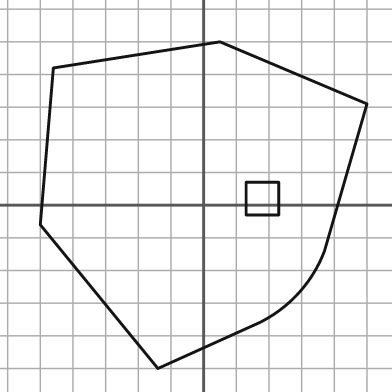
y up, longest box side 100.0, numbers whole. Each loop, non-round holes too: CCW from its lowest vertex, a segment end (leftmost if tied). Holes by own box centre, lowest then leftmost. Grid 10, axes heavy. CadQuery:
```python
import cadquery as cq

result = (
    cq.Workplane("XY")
    .moveTo(-14.0, -50.0)
    .lineTo(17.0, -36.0)
    .threePointArc((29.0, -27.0), (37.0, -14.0))
    .lineTo(50.0, 31.0)
    .lineTo(5.0, 50.0)
    .lineTo(-46.0, 42.0)
    .lineTo(-50.0, -6.0)
    .close()
    .moveTo(13.0, -3.0)
    .lineTo(23.0, -3.0)
    .lineTo(23.0, 7.0)
    .lineTo(13.0, 7.0)
    .close()
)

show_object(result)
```